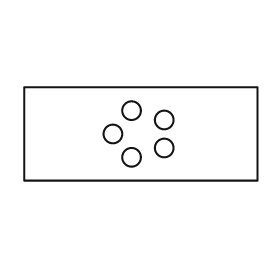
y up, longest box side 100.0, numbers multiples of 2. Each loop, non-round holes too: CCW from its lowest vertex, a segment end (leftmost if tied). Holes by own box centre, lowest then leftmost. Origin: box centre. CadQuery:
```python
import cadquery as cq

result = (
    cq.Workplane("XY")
    .moveTo(-50.0, -20.0)
    .lineTo(50.0, -20.0)
    .lineTo(50.0, 20.0)
    .lineTo(-50.0, 20.0)
    .close()
    .moveTo(-4.0, -10.0)
    .circle(4.0)
    .moveTo(10.0, -6.0)
    .circle(4.0)
    .moveTo(-12.0, 0.0)
    .circle(4.0)
    .moveTo(10.0, 6.0)
    .circle(4.0)
    .moveTo(-4.0, 10.0)
    .circle(4.0)
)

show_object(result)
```